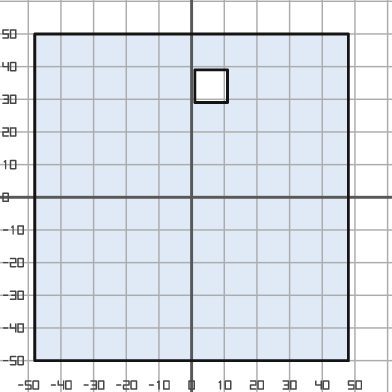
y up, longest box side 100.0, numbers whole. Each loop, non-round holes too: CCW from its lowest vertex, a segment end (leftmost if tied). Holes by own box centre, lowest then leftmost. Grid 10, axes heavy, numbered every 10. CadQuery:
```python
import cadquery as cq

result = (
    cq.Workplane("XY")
    .moveTo(-48.0, -50.0)
    .lineTo(48.0, -50.0)
    .lineTo(48.0, 50.0)
    .lineTo(-48.0, 50.0)
    .close()
    .moveTo(1.0, 29.0)
    .lineTo(11.0, 29.0)
    .lineTo(11.0, 39.0)
    .lineTo(1.0, 39.0)
    .close()
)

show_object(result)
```